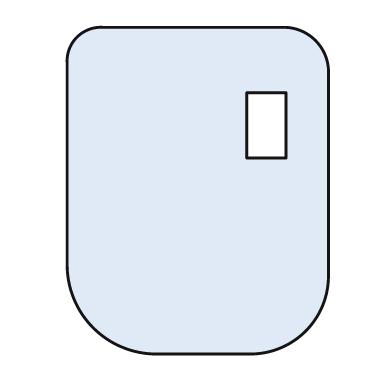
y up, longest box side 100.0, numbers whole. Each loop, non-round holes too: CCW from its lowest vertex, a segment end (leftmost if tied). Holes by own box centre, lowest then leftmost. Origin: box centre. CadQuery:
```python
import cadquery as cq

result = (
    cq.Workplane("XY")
    .moveTo(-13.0, -50.0)
    .lineTo(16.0, -50.0)
    .threePointArc((33.0, -43.0), (40.0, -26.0))
    .lineTo(40.0, 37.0)
    .threePointArc((36.0, 46.0), (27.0, 50.0))
    .lineTo(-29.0, 50.0)
    .threePointArc((-37.0, 47.0), (-40.0, 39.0))
    .lineTo(-40.0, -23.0)
    .threePointArc((-32.0, -42.0), (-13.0, -50.0))
    .close()
    .moveTo(15.0, 10.0)
    .lineTo(27.0, 10.0)
    .lineTo(27.0, 30.0)
    .lineTo(15.0, 30.0)
    .close()
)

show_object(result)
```